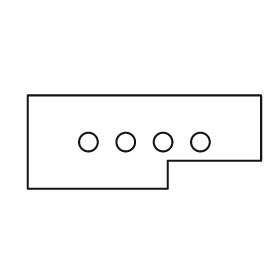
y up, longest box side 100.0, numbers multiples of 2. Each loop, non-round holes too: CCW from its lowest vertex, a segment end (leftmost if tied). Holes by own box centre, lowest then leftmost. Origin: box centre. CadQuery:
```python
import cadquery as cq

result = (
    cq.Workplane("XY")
    .moveTo(-50.0, -20.0)
    .lineTo(10.0, -20.0)
    .lineTo(10.0, -8.0)
    .lineTo(50.0, -8.0)
    .lineTo(50.0, 20.0)
    .lineTo(-50.0, 20.0)
    .close()
    .moveTo(-24.0, 0.0)
    .circle(4.0)
    .moveTo(-8.0, 0.0)
    .circle(4.0)
    .moveTo(8.0, 0.0)
    .circle(4.0)
    .moveTo(24.0, 0.0)
    .circle(4.0)
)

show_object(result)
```